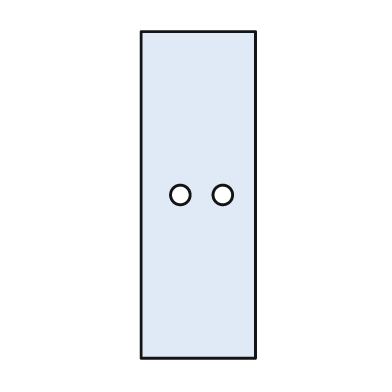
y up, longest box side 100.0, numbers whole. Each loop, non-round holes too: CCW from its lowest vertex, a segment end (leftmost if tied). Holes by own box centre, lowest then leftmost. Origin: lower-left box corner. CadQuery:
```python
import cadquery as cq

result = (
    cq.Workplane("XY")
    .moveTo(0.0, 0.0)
    .lineTo(35.0, 0.0)
    .lineTo(35.0, 100.0)
    .lineTo(0.0, 100.0)
    .close()
    .moveTo(12.0, 50.0)
    .circle(3.0)
    .moveTo(25.0, 50.0)
    .circle(3.0)
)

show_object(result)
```